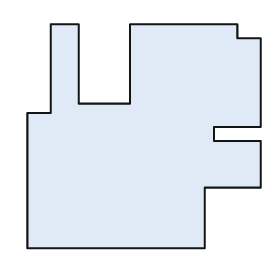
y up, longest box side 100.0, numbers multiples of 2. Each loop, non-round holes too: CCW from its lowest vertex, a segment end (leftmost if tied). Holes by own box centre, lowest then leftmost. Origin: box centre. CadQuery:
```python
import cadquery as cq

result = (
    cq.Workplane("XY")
    .moveTo(-50.0, -48.0)
    .lineTo(26.0, -48.0)
    .lineTo(26.0, -22.0)
    .lineTo(50.0, -22.0)
    .lineTo(50.0, -2.0)
    .lineTo(30.0, -2.0)
    .lineTo(30.0, 4.0)
    .lineTo(50.0, 4.0)
    .lineTo(50.0, 42.0)
    .lineTo(40.0, 42.0)
    .lineTo(40.0, 48.0)
    .lineTo(-6.0, 48.0)
    .lineTo(-6.0, 14.0)
    .lineTo(-28.0, 14.0)
    .lineTo(-28.0, 48.0)
    .lineTo(-40.0, 48.0)
    .lineTo(-40.0, 10.0)
    .lineTo(-50.0, 10.0)
    .close()
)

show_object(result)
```